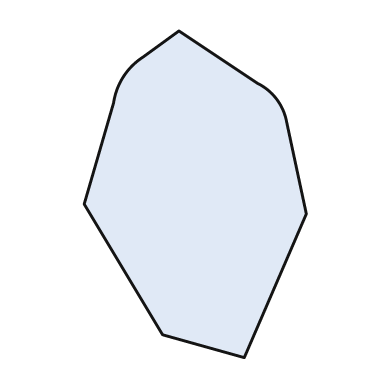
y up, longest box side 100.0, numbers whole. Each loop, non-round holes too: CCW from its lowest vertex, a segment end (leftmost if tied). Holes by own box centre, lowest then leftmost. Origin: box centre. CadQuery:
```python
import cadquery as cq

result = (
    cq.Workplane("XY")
    .moveTo(15.0, -50.0)
    .lineTo(34.0, -6.0)
    .lineTo(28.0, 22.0)
    .threePointArc((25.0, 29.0), (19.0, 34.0))
    .lineTo(-5.0, 50.0)
    .lineTo(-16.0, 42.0)
    .threePointArc((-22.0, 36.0), (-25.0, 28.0))
    .lineTo(-34.0, -3.0)
    .lineTo(-10.0, -43.0)
    .close()
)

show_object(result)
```